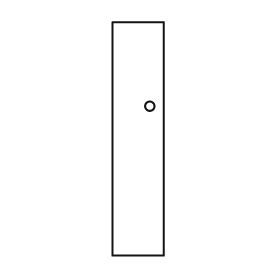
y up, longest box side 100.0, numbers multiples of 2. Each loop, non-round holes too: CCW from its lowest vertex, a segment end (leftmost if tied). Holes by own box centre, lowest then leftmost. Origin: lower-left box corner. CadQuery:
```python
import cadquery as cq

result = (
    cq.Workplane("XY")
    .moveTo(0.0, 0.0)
    .lineTo(22.0, 0.0)
    .lineTo(22.0, 100.0)
    .lineTo(0.0, 100.0)
    .close()
    .moveTo(16.0, 64.0)
    .circle(2.0)
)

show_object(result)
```